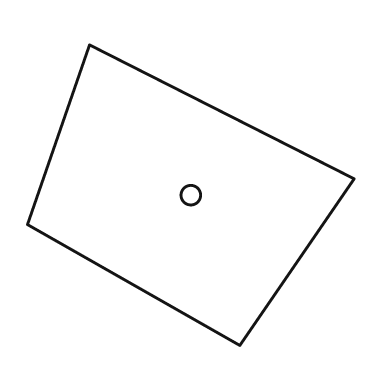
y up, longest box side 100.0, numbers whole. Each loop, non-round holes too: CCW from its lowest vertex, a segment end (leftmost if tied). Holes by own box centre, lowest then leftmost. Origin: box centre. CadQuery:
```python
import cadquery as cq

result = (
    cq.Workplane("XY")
    .moveTo(15.0, -46.0)
    .lineTo(50.0, 5.0)
    .lineTo(-31.0, 46.0)
    .lineTo(-50.0, -9.0)
    .close()
    .moveTo(0.0, 0.0)
    .circle(3.0)
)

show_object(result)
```